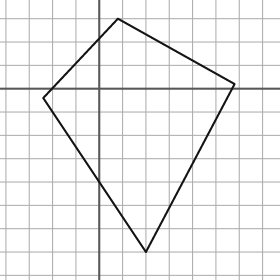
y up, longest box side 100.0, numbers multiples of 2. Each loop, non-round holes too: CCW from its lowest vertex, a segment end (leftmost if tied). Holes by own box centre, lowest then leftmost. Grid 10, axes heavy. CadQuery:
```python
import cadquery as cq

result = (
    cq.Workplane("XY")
    .moveTo(20.0, -70.0)
    .lineTo(58.0, 2.0)
    .lineTo(8.0, 30.0)
    .lineTo(-24.0, -4.0)
    .close()
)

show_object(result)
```